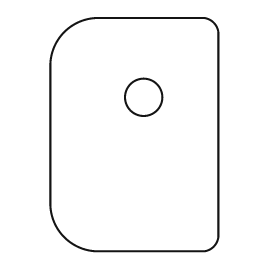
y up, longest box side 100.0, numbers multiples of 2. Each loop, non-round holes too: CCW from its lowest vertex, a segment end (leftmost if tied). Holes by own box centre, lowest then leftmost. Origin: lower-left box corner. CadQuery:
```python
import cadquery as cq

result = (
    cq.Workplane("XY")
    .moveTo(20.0, 0.0)
    .lineTo(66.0, 0.0)
    .threePointArc((70.0, 2.0), (72.0, 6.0))
    .lineTo(72.0, 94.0)
    .threePointArc((70.0, 98.0), (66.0, 100.0))
    .lineTo(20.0, 100.0)
    .threePointArc((6.0, 94.0), (0.0, 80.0))
    .lineTo(0.0, 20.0)
    .threePointArc((6.0, 6.0), (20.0, 0.0))
    .close()
    .moveTo(40.0, 66.0)
    .circle(8.0)
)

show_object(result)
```